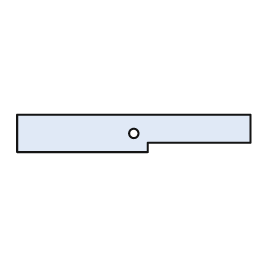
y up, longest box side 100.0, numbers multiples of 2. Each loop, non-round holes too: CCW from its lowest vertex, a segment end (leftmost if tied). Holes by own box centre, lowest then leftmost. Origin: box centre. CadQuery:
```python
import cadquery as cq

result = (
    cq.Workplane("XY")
    .moveTo(-50.0, -8.0)
    .lineTo(6.0, -8.0)
    .lineTo(6.0, -4.0)
    .lineTo(50.0, -4.0)
    .lineTo(50.0, 8.0)
    .lineTo(-50.0, 8.0)
    .close()
    .moveTo(0.0, 0.0)
    .circle(2.0)
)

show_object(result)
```